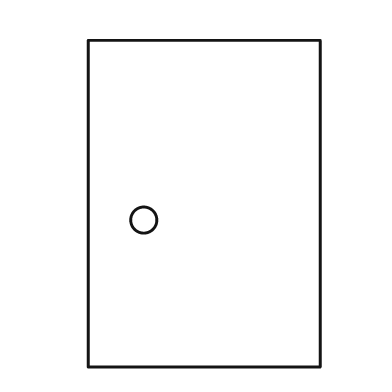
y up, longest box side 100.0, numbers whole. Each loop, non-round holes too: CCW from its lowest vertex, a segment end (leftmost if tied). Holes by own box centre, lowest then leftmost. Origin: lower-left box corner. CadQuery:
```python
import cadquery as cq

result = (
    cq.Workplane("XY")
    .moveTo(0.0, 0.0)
    .lineTo(71.0, 0.0)
    .lineTo(71.0, 100.0)
    .lineTo(0.0, 100.0)
    .close()
    .moveTo(17.0, 45.0)
    .circle(4.0)
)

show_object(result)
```